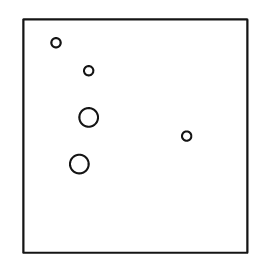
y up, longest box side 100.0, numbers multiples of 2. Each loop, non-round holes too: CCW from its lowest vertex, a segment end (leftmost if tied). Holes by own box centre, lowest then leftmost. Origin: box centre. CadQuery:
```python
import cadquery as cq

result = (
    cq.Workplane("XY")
    .moveTo(-48.0, -50.0)
    .lineTo(48.0, -50.0)
    .lineTo(48.0, 50.0)
    .lineTo(-48.0, 50.0)
    .close()
    .moveTo(-24.0, -12.0)
    .circle(4.0)
    .moveTo(22.0, 0.0)
    .circle(2.0)
    .moveTo(-20.0, 8.0)
    .circle(4.0)
    .moveTo(-20.0, 28.0)
    .circle(2.0)
    .moveTo(-34.0, 40.0)
    .circle(2.0)
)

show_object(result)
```